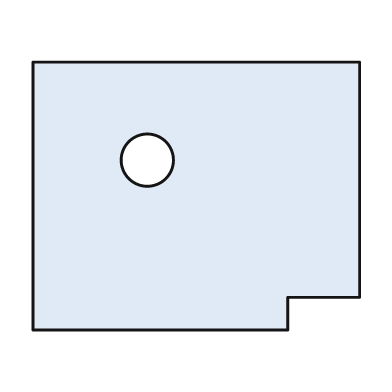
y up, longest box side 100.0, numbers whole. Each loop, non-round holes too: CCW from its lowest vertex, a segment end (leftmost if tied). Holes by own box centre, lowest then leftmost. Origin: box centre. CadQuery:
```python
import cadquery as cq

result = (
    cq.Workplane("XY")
    .moveTo(-50.0, -41.0)
    .lineTo(28.0, -41.0)
    .lineTo(28.0, -31.0)
    .lineTo(50.0, -31.0)
    .lineTo(50.0, 41.0)
    .lineTo(-50.0, 41.0)
    .close()
    .moveTo(-15.0, 11.0)
    .circle(8.0)
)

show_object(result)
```